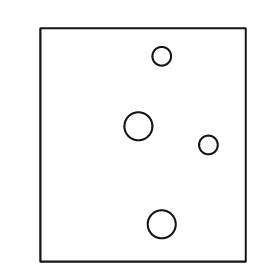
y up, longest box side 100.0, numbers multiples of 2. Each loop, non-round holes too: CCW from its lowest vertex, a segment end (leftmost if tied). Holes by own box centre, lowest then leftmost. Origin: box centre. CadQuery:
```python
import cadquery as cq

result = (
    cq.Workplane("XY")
    .moveTo(-44.0, -50.0)
    .lineTo(44.0, -50.0)
    .lineTo(44.0, 50.0)
    .lineTo(-44.0, 50.0)
    .close()
    .moveTo(8.0, -34.0)
    .circle(6.0)
    .moveTo(28.0, 0.0)
    .circle(4.0)
    .moveTo(-2.0, 8.0)
    .circle(6.0)
    .moveTo(8.0, 38.0)
    .circle(4.0)
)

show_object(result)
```